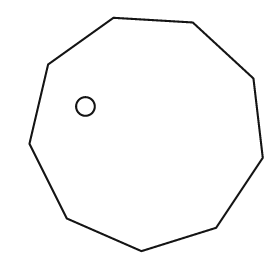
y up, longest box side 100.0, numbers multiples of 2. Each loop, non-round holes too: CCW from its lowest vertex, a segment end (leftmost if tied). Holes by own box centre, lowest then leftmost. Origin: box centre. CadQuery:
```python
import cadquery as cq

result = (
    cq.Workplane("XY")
    .moveTo(-2.0, -50.0)
    .lineTo(30.0, -40.0)
    .lineTo(50.0, -10.0)
    .lineTo(46.0, 24.0)
    .lineTo(20.0, 48.0)
    .lineTo(-14.0, 50.0)
    .lineTo(-42.0, 30.0)
    .lineTo(-50.0, -4.0)
    .lineTo(-34.0, -36.0)
    .close()
    .moveTo(-26.0, 12.0)
    .circle(4.0)
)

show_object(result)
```